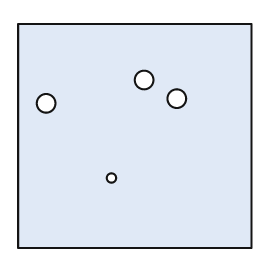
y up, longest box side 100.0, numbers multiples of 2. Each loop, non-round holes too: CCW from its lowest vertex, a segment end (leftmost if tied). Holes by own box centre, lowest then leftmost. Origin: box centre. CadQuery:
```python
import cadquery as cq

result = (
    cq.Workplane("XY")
    .moveTo(-50.0, -48.0)
    .lineTo(50.0, -48.0)
    .lineTo(50.0, 48.0)
    .lineTo(-50.0, 48.0)
    .close()
    .moveTo(-10.0, -18.0)
    .circle(2.0)
    .moveTo(-38.0, 14.0)
    .circle(4.0)
    .moveTo(18.0, 16.0)
    .circle(4.0)
    .moveTo(4.0, 24.0)
    .circle(4.0)
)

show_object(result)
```